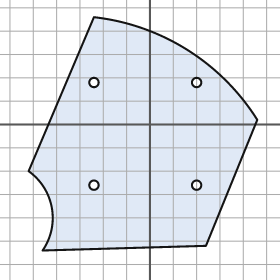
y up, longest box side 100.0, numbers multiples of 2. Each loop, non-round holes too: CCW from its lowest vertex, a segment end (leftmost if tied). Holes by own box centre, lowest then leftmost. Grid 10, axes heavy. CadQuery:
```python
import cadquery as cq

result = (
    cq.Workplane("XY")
    .moveTo(-46.0, -54.0)
    .lineTo(24.0, -52.0)
    .lineTo(46.0, 2.0)
    .threePointArc((16.0, 32.0), (-24.0, 46.0))
    .lineTo(-52.0, -20.0)
    .threePointArc((-42.0, -36.0), (-46.0, -54.0))
    .close()
    .moveTo(-24.0, -26.0)
    .circle(2.0)
    .moveTo(20.0, -26.0)
    .circle(2.0)
    .moveTo(-24.0, 18.0)
    .circle(2.0)
    .moveTo(20.0, 18.0)
    .circle(2.0)
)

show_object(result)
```